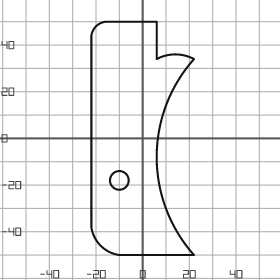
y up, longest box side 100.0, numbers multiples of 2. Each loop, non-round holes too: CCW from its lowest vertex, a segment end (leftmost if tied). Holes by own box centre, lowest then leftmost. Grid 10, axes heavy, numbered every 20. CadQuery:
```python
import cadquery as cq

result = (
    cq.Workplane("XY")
    .moveTo(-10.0, -50.0)
    .lineTo(22.0, -50.0)
    .threePointArc((6.0, -8.0), (22.0, 34.0))
    .threePointArc((14.0, 36.0), (6.0, 34.0))
    .lineTo(6.0, 50.0)
    .lineTo(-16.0, 50.0)
    .threePointArc((-20.0, 48.0), (-22.0, 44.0))
    .lineTo(-22.0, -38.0)
    .threePointArc((-18.0, -46.0), (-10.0, -50.0))
    .close()
    .moveTo(-10.0, -18.0)
    .circle(4.0)
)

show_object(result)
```